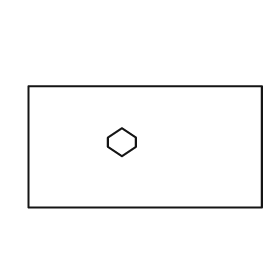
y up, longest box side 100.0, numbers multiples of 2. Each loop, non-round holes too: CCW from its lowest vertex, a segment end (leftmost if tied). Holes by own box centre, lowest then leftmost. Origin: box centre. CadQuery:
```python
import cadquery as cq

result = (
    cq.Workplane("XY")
    .moveTo(-50.0, -26.0)
    .lineTo(50.0, -26.0)
    .lineTo(50.0, 26.0)
    .lineTo(-50.0, 26.0)
    .close()
    .moveTo(-10.0, -4.0)
    .lineTo(-4.0, 0.0)
    .lineTo(-4.0, 4.0)
    .lineTo(-10.0, 8.0)
    .lineTo(-16.0, 4.0)
    .lineTo(-16.0, 0.0)
    .close()
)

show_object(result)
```